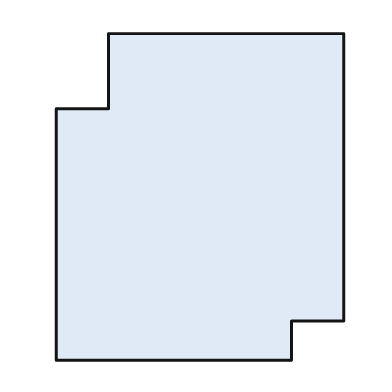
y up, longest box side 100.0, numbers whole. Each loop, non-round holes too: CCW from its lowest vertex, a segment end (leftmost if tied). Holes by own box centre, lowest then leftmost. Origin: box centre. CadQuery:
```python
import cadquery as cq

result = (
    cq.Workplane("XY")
    .moveTo(-44.0, -50.0)
    .lineTo(28.0, -50.0)
    .lineTo(28.0, -38.0)
    .lineTo(44.0, -38.0)
    .lineTo(44.0, 50.0)
    .lineTo(-28.0, 50.0)
    .lineTo(-28.0, 27.0)
    .lineTo(-44.0, 27.0)
    .close()
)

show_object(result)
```